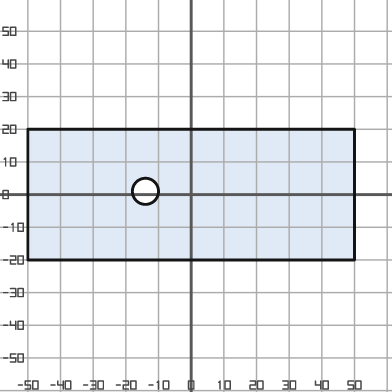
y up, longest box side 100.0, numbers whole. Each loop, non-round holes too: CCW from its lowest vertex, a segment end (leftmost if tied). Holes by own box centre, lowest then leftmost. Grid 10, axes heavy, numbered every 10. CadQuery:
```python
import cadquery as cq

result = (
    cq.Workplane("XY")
    .moveTo(-50.0, -20.0)
    .lineTo(50.0, -20.0)
    .lineTo(50.0, 20.0)
    .lineTo(-50.0, 20.0)
    .close()
    .moveTo(-14.0, 1.0)
    .circle(4.0)
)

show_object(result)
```